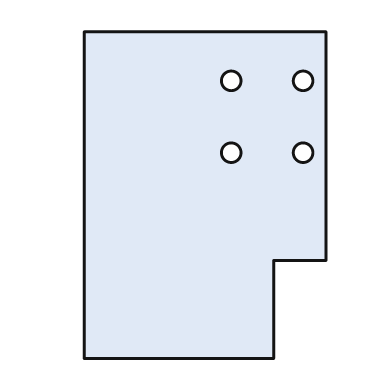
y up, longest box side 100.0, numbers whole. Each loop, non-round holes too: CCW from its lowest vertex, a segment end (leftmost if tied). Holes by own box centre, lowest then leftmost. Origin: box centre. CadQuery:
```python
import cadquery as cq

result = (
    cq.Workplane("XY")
    .moveTo(-37.0, -50.0)
    .lineTo(21.0, -50.0)
    .lineTo(21.0, -20.0)
    .lineTo(37.0, -20.0)
    .lineTo(37.0, 50.0)
    .lineTo(-37.0, 50.0)
    .close()
    .moveTo(8.0, 13.0)
    .circle(3.0)
    .moveTo(30.0, 13.0)
    .circle(3.0)
    .moveTo(8.0, 35.0)
    .circle(3.0)
    .moveTo(30.0, 35.0)
    .circle(3.0)
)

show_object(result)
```